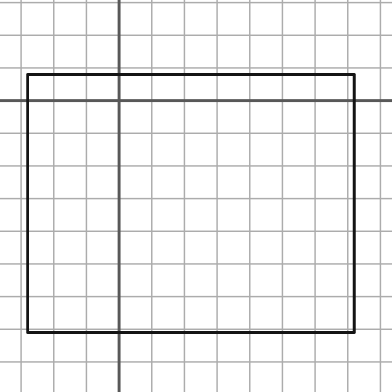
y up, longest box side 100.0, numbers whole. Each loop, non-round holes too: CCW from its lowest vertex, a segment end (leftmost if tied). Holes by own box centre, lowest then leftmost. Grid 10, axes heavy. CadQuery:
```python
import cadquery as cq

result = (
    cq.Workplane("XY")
    .moveTo(-28.0, -71.0)
    .lineTo(72.0, -71.0)
    .lineTo(72.0, 8.0)
    .lineTo(-28.0, 8.0)
    .close()
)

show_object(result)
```